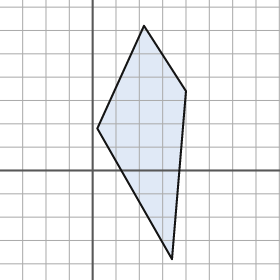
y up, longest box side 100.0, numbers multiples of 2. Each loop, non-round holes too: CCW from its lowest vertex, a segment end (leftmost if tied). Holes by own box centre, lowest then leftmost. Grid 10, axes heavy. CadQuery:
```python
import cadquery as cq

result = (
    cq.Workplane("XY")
    .moveTo(34.0, -38.0)
    .lineTo(40.0, 34.0)
    .lineTo(22.0, 62.0)
    .lineTo(2.0, 18.0)
    .close()
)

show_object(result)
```